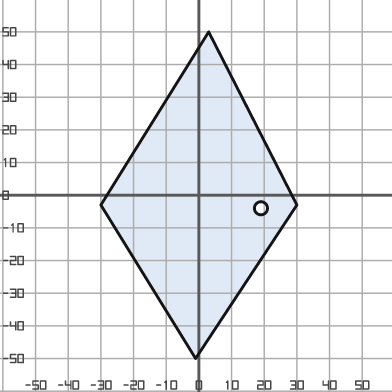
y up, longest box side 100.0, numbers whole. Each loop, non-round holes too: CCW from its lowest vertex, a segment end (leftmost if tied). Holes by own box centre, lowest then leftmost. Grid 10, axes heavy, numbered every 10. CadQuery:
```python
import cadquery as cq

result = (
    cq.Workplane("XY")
    .moveTo(-1.0, -50.0)
    .lineTo(30.0, -3.0)
    .lineTo(3.0, 50.0)
    .lineTo(-30.0, -3.0)
    .close()
    .moveTo(19.0, -4.0)
    .circle(2.0)
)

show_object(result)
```